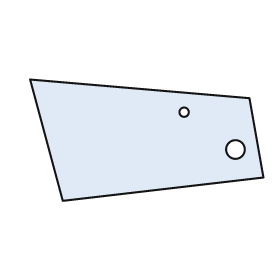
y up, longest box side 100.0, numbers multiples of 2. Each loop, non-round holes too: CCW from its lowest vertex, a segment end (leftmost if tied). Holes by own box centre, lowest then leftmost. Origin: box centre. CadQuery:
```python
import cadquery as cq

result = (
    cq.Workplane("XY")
    .moveTo(-36.0, -26.0)
    .lineTo(50.0, -16.0)
    .lineTo(44.0, 18.0)
    .lineTo(-50.0, 26.0)
    .close()
    .moveTo(38.0, -4.0)
    .circle(4.0)
    .moveTo(16.0, 12.0)
    .circle(2.0)
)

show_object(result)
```